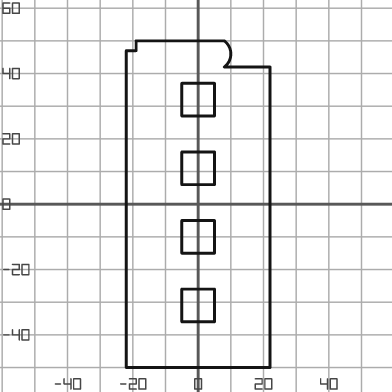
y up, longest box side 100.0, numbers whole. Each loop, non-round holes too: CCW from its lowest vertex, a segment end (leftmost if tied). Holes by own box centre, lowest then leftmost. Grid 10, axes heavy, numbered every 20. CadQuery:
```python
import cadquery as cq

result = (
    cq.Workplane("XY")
    .moveTo(-22.0, -50.0)
    .lineTo(22.0, -50.0)
    .lineTo(22.0, 42.0)
    .lineTo(8.0, 42.0)
    .threePointArc((10.0, 46.0), (8.0, 50.0))
    .lineTo(-19.0, 50.0)
    .lineTo(-19.0, 47.0)
    .lineTo(-22.0, 47.0)
    .close()
    .moveTo(-5.0, -36.0)
    .lineTo(5.0, -36.0)
    .lineTo(5.0, -26.0)
    .lineTo(-5.0, -26.0)
    .close()
    .moveTo(-5.0, -15.0)
    .lineTo(5.0, -15.0)
    .lineTo(5.0, -5.0)
    .lineTo(-5.0, -5.0)
    .close()
    .moveTo(-5.0, 6.0)
    .lineTo(5.0, 6.0)
    .lineTo(5.0, 16.0)
    .lineTo(-5.0, 16.0)
    .close()
    .moveTo(-5.0, 27.0)
    .lineTo(5.0, 27.0)
    .lineTo(5.0, 37.0)
    .lineTo(-5.0, 37.0)
    .close()
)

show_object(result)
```